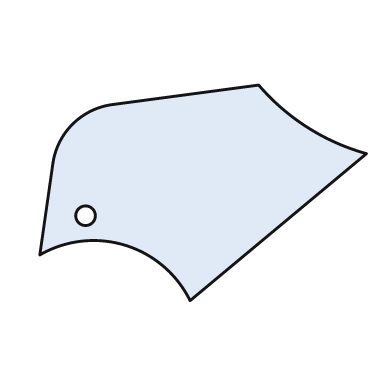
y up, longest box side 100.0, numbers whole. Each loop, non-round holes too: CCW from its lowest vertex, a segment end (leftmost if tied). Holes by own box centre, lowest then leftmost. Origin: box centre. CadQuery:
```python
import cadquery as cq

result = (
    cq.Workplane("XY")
    .moveTo(-4.0, -33.0)
    .lineTo(50.0, 12.0)
    .threePointArc((32.0, 20.0), (17.0, 33.0))
    .lineTo(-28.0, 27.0)
    .threePointArc((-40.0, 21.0), (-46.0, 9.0))
    .lineTo(-50.0, -19.0)
    .threePointArc((-24.0, -16.0), (-4.0, -33.0))
    .close()
    .moveTo(-36.0, -7.0)
    .circle(3.0)
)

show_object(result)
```